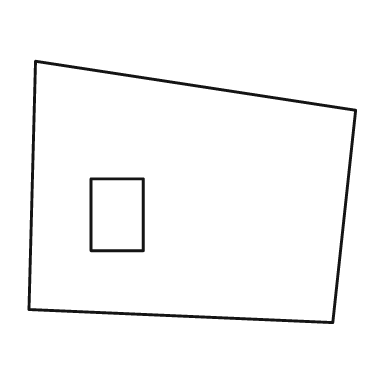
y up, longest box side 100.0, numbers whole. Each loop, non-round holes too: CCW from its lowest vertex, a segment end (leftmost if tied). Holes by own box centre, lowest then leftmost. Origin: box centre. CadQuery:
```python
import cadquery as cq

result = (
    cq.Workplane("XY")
    .moveTo(43.0, -40.0)
    .lineTo(50.0, 25.0)
    .lineTo(-48.0, 40.0)
    .lineTo(-50.0, -36.0)
    .close()
    .moveTo(-31.0, -18.0)
    .lineTo(-15.0, -18.0)
    .lineTo(-15.0, 4.0)
    .lineTo(-31.0, 4.0)
    .close()
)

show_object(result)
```